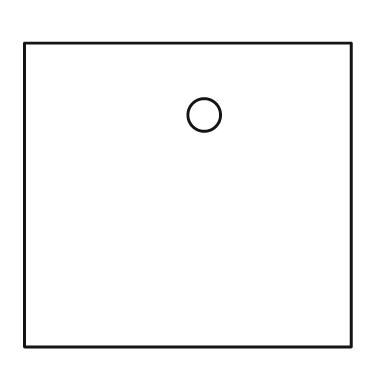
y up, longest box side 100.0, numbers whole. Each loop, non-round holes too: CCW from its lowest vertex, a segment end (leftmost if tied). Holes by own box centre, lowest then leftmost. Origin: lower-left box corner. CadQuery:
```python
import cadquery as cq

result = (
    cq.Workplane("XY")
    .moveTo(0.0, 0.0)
    .lineTo(100.0, 0.0)
    .lineTo(100.0, 93.0)
    .lineTo(0.0, 93.0)
    .close()
    .moveTo(55.0, 71.0)
    .circle(5.0)
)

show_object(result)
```